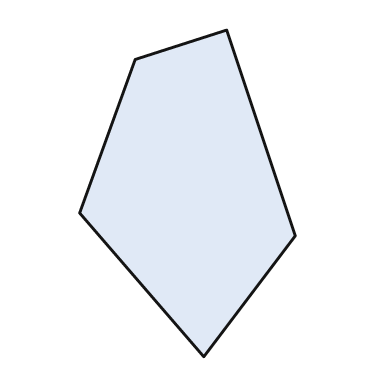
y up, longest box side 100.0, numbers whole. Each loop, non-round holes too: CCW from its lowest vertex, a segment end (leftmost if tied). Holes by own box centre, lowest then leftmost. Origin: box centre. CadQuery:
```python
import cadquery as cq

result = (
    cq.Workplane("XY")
    .moveTo(5.0, -50.0)
    .lineTo(33.0, -13.0)
    .lineTo(12.0, 50.0)
    .lineTo(-16.0, 41.0)
    .lineTo(-33.0, -6.0)
    .close()
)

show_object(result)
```